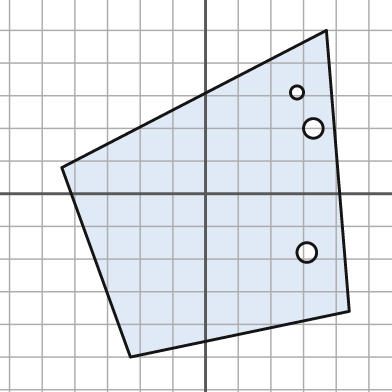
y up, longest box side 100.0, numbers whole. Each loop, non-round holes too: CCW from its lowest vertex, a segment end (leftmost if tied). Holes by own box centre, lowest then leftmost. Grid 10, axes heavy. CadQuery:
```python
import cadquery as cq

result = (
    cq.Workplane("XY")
    .moveTo(-23.0, -50.0)
    .lineTo(44.0, -36.0)
    .lineTo(37.0, 50.0)
    .lineTo(-44.0, 8.0)
    .close()
    .moveTo(31.0, -18.0)
    .circle(3.0)
    .moveTo(33.0, 20.0)
    .circle(3.0)
    .moveTo(28.0, 31.0)
    .circle(2.0)
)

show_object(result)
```